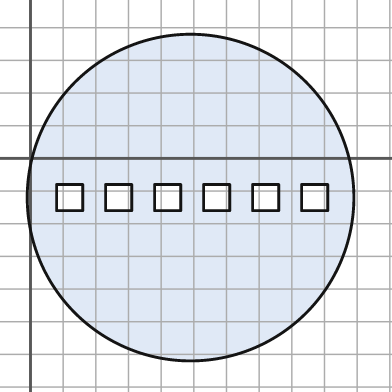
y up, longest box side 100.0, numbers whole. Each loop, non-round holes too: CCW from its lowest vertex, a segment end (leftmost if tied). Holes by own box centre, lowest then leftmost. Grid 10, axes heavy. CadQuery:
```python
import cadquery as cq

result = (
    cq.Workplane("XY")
    .moveTo(49.0, -12.0)
    .circle(50.0)
    .moveTo(8.0, -16.0)
    .lineTo(16.0, -16.0)
    .lineTo(16.0, -8.0)
    .lineTo(8.0, -8.0)
    .close()
    .moveTo(23.0, -16.0)
    .lineTo(31.0, -16.0)
    .lineTo(31.0, -8.0)
    .lineTo(23.0, -8.0)
    .close()
    .moveTo(38.0, -16.0)
    .lineTo(46.0, -16.0)
    .lineTo(46.0, -8.0)
    .lineTo(38.0, -8.0)
    .close()
    .moveTo(53.0, -16.0)
    .lineTo(61.0, -16.0)
    .lineTo(61.0, -8.0)
    .lineTo(53.0, -8.0)
    .close()
    .moveTo(68.0, -16.0)
    .lineTo(76.0, -16.0)
    .lineTo(76.0, -8.0)
    .lineTo(68.0, -8.0)
    .close()
    .moveTo(83.0, -16.0)
    .lineTo(91.0, -16.0)
    .lineTo(91.0, -8.0)
    .lineTo(83.0, -8.0)
    .close()
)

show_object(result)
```